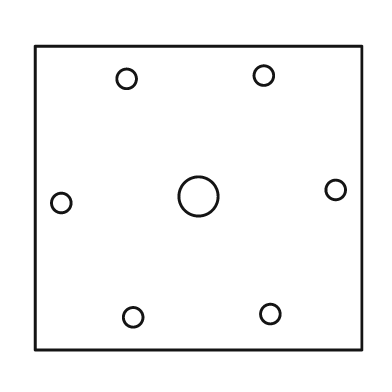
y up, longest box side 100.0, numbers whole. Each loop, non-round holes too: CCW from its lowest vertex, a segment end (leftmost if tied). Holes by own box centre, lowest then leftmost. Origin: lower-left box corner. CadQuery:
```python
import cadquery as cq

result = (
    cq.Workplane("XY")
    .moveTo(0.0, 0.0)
    .lineTo(100.0, 0.0)
    .lineTo(100.0, 93.0)
    .lineTo(0.0, 93.0)
    .close()
    .moveTo(30.0, 10.0)
    .circle(3.0)
    .moveTo(72.0, 11.0)
    .circle(3.0)
    .moveTo(8.0, 45.0)
    .circle(3.0)
    .moveTo(50.0, 47.0)
    .circle(6.0)
    .moveTo(92.0, 49.0)
    .circle(3.0)
    .moveTo(28.0, 83.0)
    .circle(3.0)
    .moveTo(70.0, 84.0)
    .circle(3.0)
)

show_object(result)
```